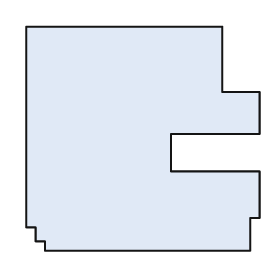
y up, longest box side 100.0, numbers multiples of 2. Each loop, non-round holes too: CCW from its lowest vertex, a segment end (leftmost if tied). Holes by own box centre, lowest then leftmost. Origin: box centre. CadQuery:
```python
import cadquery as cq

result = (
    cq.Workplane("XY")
    .moveTo(-42.0, -48.0)
    .lineTo(46.0, -48.0)
    .lineTo(46.0, -34.0)
    .lineTo(50.0, -34.0)
    .lineTo(50.0, -14.0)
    .lineTo(12.0, -14.0)
    .lineTo(12.0, 2.0)
    .lineTo(50.0, 2.0)
    .lineTo(50.0, 20.0)
    .lineTo(34.0, 20.0)
    .lineTo(34.0, 48.0)
    .lineTo(-50.0, 48.0)
    .lineTo(-50.0, -38.0)
    .lineTo(-46.0, -38.0)
    .lineTo(-46.0, -44.0)
    .lineTo(-42.0, -44.0)
    .close()
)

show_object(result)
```